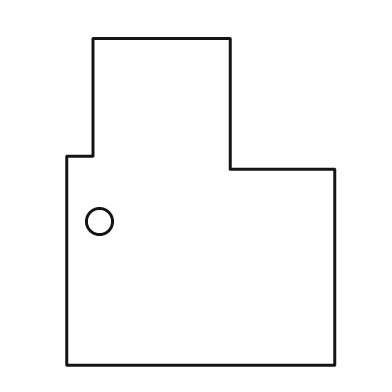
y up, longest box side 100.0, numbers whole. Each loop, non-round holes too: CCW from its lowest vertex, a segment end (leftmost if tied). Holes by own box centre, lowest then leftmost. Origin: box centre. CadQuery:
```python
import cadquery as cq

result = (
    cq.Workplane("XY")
    .moveTo(-41.0, -50.0)
    .lineTo(41.0, -50.0)
    .lineTo(41.0, 10.0)
    .lineTo(9.0, 10.0)
    .lineTo(9.0, 50.0)
    .lineTo(-33.0, 50.0)
    .lineTo(-33.0, 14.0)
    .lineTo(-41.0, 14.0)
    .close()
    .moveTo(-31.0, -6.0)
    .circle(4.0)
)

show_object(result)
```